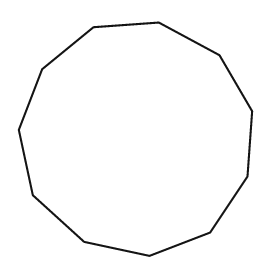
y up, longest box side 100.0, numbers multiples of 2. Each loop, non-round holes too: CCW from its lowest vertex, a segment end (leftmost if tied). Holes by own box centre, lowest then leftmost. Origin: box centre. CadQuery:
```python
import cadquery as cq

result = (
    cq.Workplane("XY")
    .moveTo(6.0, -50.0)
    .lineTo(32.0, -40.0)
    .lineTo(48.0, -16.0)
    .lineTo(50.0, 12.0)
    .lineTo(36.0, 36.0)
    .lineTo(10.0, 50.0)
    .lineTo(-18.0, 48.0)
    .lineTo(-40.0, 30.0)
    .lineTo(-50.0, 4.0)
    .lineTo(-44.0, -24.0)
    .lineTo(-22.0, -44.0)
    .close()
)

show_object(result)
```